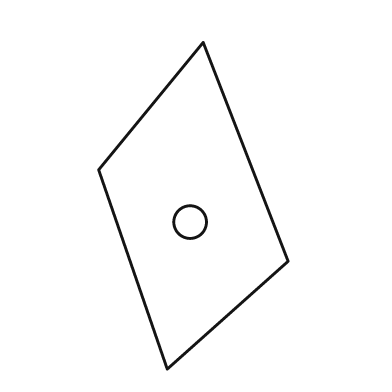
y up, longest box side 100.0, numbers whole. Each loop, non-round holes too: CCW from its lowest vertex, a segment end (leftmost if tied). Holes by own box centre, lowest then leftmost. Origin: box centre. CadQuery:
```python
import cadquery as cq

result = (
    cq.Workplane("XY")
    .moveTo(-8.0, -50.0)
    .lineTo(29.0, -17.0)
    .lineTo(3.0, 50.0)
    .lineTo(-29.0, 11.0)
    .close()
    .moveTo(-1.0, -5.0)
    .circle(5.0)
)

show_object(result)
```